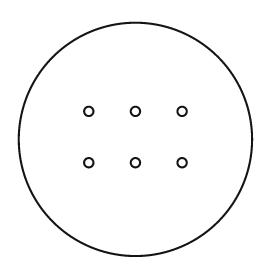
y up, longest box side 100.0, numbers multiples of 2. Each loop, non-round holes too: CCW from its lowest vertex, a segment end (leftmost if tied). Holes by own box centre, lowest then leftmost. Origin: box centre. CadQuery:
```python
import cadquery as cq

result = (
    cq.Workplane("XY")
    .moveTo(0.0, 0.0)
    .circle(50.0)
    .moveTo(-20.0, -10.0)
    .circle(2.0)
    .moveTo(0.0, -10.0)
    .circle(2.0)
    .moveTo(20.0, -10.0)
    .circle(2.0)
    .moveTo(-20.0, 12.0)
    .circle(2.0)
    .moveTo(0.0, 12.0)
    .circle(2.0)
    .moveTo(20.0, 12.0)
    .circle(2.0)
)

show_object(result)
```